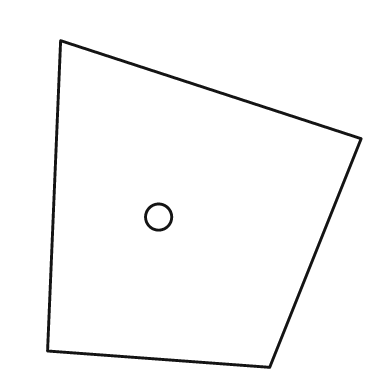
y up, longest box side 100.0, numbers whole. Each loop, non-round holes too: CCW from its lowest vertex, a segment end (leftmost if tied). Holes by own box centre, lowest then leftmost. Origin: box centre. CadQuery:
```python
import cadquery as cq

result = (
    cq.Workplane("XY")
    .moveTo(20.0, -50.0)
    .lineTo(48.0, 20.0)
    .lineTo(-44.0, 50.0)
    .lineTo(-48.0, -45.0)
    .close()
    .moveTo(-14.0, -4.0)
    .circle(4.0)
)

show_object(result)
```